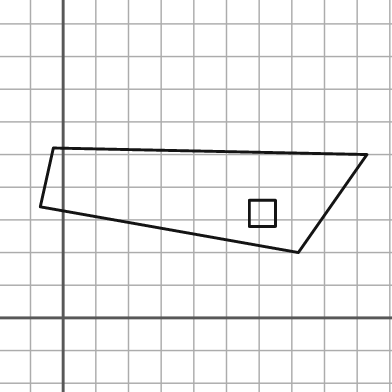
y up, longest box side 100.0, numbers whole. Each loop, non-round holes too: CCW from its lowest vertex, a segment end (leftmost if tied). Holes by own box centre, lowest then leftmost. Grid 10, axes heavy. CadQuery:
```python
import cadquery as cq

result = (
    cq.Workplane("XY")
    .moveTo(72.0, 20.0)
    .lineTo(93.0, 50.0)
    .lineTo(-3.0, 52.0)
    .lineTo(-7.0, 34.0)
    .close()
    .moveTo(57.0, 28.0)
    .lineTo(65.0, 28.0)
    .lineTo(65.0, 36.0)
    .lineTo(57.0, 36.0)
    .close()
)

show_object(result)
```